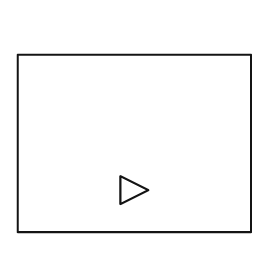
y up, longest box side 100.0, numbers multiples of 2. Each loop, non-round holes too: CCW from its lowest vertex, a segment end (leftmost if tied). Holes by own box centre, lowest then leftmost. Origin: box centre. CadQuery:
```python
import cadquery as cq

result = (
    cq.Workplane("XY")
    .moveTo(-50.0, -38.0)
    .lineTo(50.0, -38.0)
    .lineTo(50.0, 38.0)
    .lineTo(-50.0, 38.0)
    .close()
    .moveTo(-6.0, -26.0)
    .lineTo(6.0, -20.0)
    .lineTo(-6.0, -14.0)
    .close()
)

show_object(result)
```